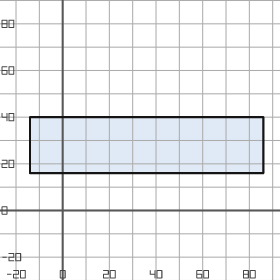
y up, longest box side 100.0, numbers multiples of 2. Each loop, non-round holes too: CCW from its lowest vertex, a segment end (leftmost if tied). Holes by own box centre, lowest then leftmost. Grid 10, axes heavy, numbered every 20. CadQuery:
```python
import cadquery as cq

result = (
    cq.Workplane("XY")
    .moveTo(-14.0, 16.0)
    .lineTo(86.0, 16.0)
    .lineTo(86.0, 40.0)
    .lineTo(-14.0, 40.0)
    .close()
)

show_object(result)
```